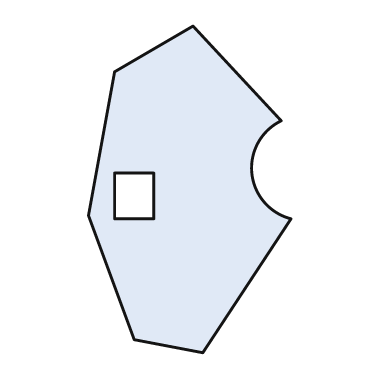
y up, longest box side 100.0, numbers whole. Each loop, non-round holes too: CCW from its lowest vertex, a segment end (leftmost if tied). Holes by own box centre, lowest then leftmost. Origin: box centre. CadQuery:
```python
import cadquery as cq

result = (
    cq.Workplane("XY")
    .moveTo(4.0, -50.0)
    .lineTo(31.0, -9.0)
    .threePointArc((19.0, 5.0), (28.0, 21.0))
    .lineTo(1.0, 50.0)
    .lineTo(-23.0, 36.0)
    .lineTo(-31.0, -8.0)
    .lineTo(-17.0, -46.0)
    .close()
    .moveTo(-23.0, -9.0)
    .lineTo(-11.0, -9.0)
    .lineTo(-11.0, 5.0)
    .lineTo(-23.0, 5.0)
    .close()
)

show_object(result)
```